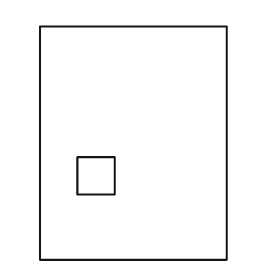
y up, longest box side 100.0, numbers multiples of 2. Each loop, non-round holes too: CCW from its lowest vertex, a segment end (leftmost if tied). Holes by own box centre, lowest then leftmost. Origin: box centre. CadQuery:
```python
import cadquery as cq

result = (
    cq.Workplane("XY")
    .moveTo(-40.0, -50.0)
    .lineTo(40.0, -50.0)
    .lineTo(40.0, 50.0)
    .lineTo(-40.0, 50.0)
    .close()
    .moveTo(-24.0, -22.0)
    .lineTo(-8.0, -22.0)
    .lineTo(-8.0, -6.0)
    .lineTo(-24.0, -6.0)
    .close()
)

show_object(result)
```